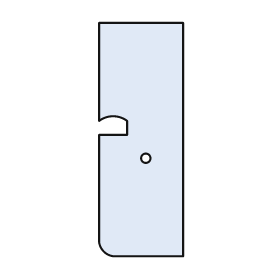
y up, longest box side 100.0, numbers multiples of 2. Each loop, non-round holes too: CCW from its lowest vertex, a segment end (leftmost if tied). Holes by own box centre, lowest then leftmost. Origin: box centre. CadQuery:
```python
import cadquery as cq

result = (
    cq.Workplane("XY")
    .moveTo(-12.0, -50.0)
    .lineTo(18.0, -50.0)
    .lineTo(18.0, 50.0)
    .lineTo(-18.0, 50.0)
    .lineTo(-18.0, 8.0)
    .threePointArc((-12.0, 10.0), (-6.0, 8.0))
    .lineTo(-6.0, 2.0)
    .lineTo(-18.0, 2.0)
    .lineTo(-18.0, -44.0)
    .threePointArc((-16.0, -48.0), (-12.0, -50.0))
    .close()
    .moveTo(2.0, -8.0)
    .circle(2.0)
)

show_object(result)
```